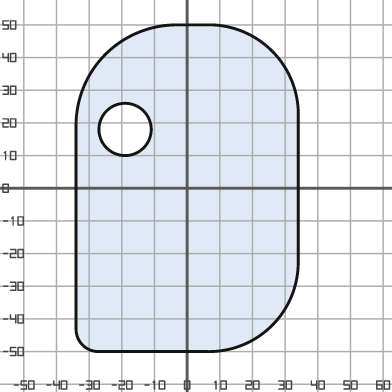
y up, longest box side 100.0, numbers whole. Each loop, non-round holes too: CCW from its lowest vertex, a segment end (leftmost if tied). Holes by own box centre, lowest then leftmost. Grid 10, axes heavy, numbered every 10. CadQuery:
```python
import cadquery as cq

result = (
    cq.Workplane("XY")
    .moveTo(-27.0, -50.0)
    .lineTo(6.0, -50.0)
    .threePointArc((26.0, -42.0), (34.0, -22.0))
    .lineTo(34.0, 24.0)
    .threePointArc((26.0, 42.0), (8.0, 50.0))
    .lineTo(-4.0, 50.0)
    .threePointArc((-25.0, 41.0), (-34.0, 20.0))
    .lineTo(-34.0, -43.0)
    .threePointArc((-32.0, -48.0), (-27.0, -50.0))
    .close()
    .moveTo(-19.0, 18.0)
    .circle(8.0)
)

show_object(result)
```